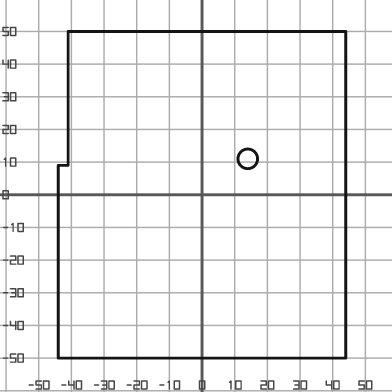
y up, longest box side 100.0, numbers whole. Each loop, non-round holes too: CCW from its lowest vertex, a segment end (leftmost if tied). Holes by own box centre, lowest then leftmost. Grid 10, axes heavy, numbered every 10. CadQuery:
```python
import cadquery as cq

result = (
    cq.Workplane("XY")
    .moveTo(-44.0, -50.0)
    .lineTo(44.0, -50.0)
    .lineTo(44.0, 50.0)
    .lineTo(-41.0, 50.0)
    .lineTo(-41.0, 9.0)
    .lineTo(-44.0, 9.0)
    .close()
    .moveTo(14.0, 11.0)
    .circle(3.0)
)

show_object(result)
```